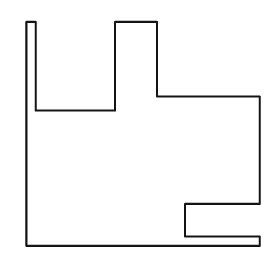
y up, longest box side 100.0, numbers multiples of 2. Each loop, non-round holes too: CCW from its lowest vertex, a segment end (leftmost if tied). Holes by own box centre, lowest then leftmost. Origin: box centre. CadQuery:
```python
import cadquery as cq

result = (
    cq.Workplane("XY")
    .moveTo(-50.0, -48.0)
    .lineTo(50.0, -48.0)
    .lineTo(50.0, -44.0)
    .lineTo(18.0, -44.0)
    .lineTo(18.0, -30.0)
    .lineTo(50.0, -30.0)
    .lineTo(50.0, 16.0)
    .lineTo(6.0, 16.0)
    .lineTo(6.0, 48.0)
    .lineTo(-12.0, 48.0)
    .lineTo(-12.0, 10.0)
    .lineTo(-46.0, 10.0)
    .lineTo(-46.0, 48.0)
    .lineTo(-50.0, 48.0)
    .close()
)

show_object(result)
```